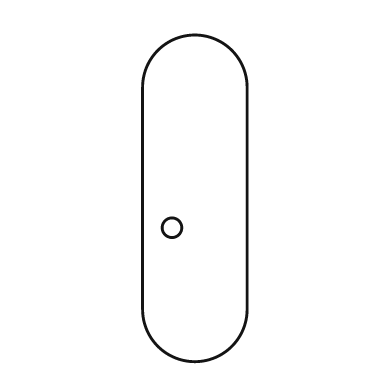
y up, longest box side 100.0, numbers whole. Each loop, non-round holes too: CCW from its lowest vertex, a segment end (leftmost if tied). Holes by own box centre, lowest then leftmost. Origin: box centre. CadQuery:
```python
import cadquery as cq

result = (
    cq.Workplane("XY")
    .moveTo(-16.0, -34.0)
    .threePointArc((0.0, -50.0), (16.0, -34.0))
    .lineTo(16.0, 34.0)
    .threePointArc((0.0, 50.0), (-16.0, 34.0))
    .close()
    .moveTo(-7.0, -9.0)
    .circle(3.0)
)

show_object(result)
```